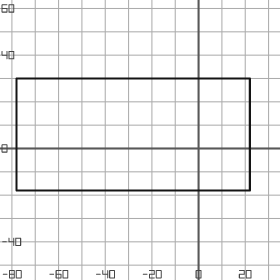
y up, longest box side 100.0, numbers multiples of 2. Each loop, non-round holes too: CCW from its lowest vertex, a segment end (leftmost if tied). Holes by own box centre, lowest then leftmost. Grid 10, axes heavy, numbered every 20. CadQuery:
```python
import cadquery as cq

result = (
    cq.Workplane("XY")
    .moveTo(-78.0, -18.0)
    .lineTo(22.0, -18.0)
    .lineTo(22.0, 30.0)
    .lineTo(-78.0, 30.0)
    .close()
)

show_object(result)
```